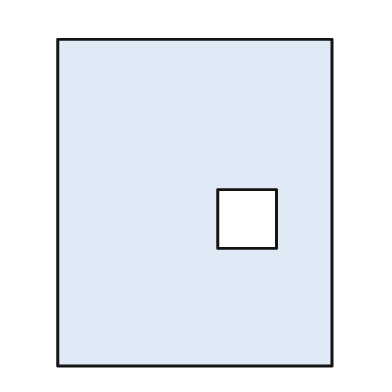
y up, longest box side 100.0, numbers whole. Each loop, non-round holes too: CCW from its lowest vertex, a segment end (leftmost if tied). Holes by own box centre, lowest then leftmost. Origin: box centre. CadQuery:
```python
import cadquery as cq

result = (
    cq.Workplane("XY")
    .moveTo(-42.0, -50.0)
    .lineTo(42.0, -50.0)
    .lineTo(42.0, 50.0)
    .lineTo(-42.0, 50.0)
    .close()
    .moveTo(7.0, -14.0)
    .lineTo(25.0, -14.0)
    .lineTo(25.0, 4.0)
    .lineTo(7.0, 4.0)
    .close()
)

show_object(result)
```